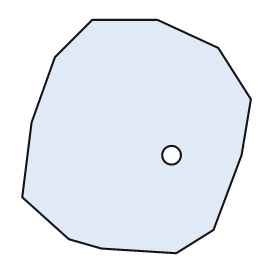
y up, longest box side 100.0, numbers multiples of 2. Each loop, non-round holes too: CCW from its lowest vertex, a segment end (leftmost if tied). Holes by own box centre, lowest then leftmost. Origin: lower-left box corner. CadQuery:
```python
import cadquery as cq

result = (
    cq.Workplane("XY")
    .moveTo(66.0, 0.0)
    .lineTo(82.0, 10.0)
    .lineTo(94.0, 42.0)
    .lineTo(98.0, 66.0)
    .lineTo(84.0, 88.0)
    .lineTo(58.0, 100.0)
    .lineTo(30.0, 100.0)
    .lineTo(14.0, 84.0)
    .lineTo(4.0, 56.0)
    .lineTo(0.0, 24.0)
    .lineTo(20.0, 6.0)
    .lineTo(34.0, 2.0)
    .close()
    .moveTo(64.0, 42.0)
    .circle(4.0)
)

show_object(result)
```